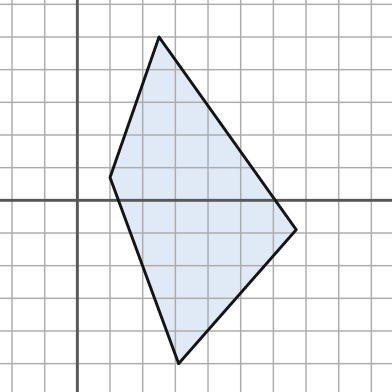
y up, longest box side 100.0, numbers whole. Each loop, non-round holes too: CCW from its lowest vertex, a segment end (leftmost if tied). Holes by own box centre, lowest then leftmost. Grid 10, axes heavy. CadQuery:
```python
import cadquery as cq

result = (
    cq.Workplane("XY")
    .moveTo(31.0, -50.0)
    .lineTo(67.0, -9.0)
    .lineTo(25.0, 50.0)
    .lineTo(10.0, 7.0)
    .close()
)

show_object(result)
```